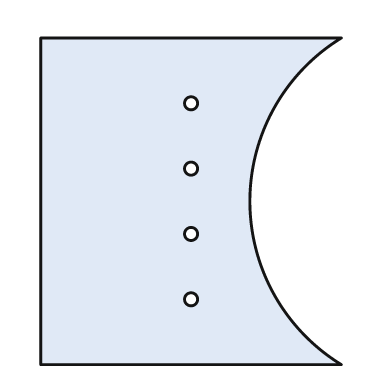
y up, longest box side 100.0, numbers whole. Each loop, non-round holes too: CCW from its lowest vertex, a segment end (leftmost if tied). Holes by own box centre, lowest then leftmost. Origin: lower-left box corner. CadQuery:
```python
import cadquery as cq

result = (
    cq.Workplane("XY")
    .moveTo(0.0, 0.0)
    .lineTo(92.0, 0.0)
    .threePointArc((64.0, 50.0), (92.0, 100.0))
    .lineTo(0.0, 100.0)
    .close()
    .moveTo(46.0, 20.0)
    .circle(2.0)
    .moveTo(46.0, 40.0)
    .circle(2.0)
    .moveTo(46.0, 60.0)
    .circle(2.0)
    .moveTo(46.0, 80.0)
    .circle(2.0)
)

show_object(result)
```